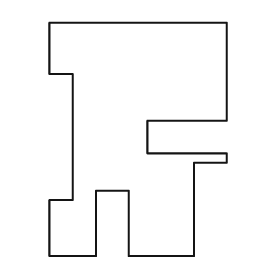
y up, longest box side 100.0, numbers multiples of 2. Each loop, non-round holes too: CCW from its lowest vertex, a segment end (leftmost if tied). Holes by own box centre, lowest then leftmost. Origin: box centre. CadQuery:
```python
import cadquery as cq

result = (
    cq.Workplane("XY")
    .moveTo(-38.0, -50.0)
    .lineTo(-18.0, -50.0)
    .lineTo(-18.0, -22.0)
    .lineTo(-4.0, -22.0)
    .lineTo(-4.0, -50.0)
    .lineTo(24.0, -50.0)
    .lineTo(24.0, -10.0)
    .lineTo(38.0, -10.0)
    .lineTo(38.0, -6.0)
    .lineTo(4.0, -6.0)
    .lineTo(4.0, 8.0)
    .lineTo(38.0, 8.0)
    .lineTo(38.0, 50.0)
    .lineTo(-38.0, 50.0)
    .lineTo(-38.0, 28.0)
    .lineTo(-28.0, 28.0)
    .lineTo(-28.0, -26.0)
    .lineTo(-38.0, -26.0)
    .close()
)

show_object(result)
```